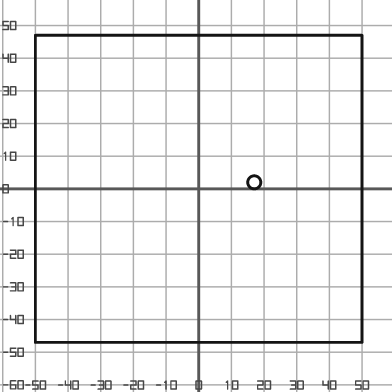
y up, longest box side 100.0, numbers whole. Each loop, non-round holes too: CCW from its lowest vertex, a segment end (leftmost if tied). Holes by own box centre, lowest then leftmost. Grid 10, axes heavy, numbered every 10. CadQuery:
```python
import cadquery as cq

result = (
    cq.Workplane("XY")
    .moveTo(-50.0, -47.0)
    .lineTo(50.0, -47.0)
    .lineTo(50.0, 47.0)
    .lineTo(-50.0, 47.0)
    .close()
    .moveTo(17.0, 2.0)
    .circle(2.0)
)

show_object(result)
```